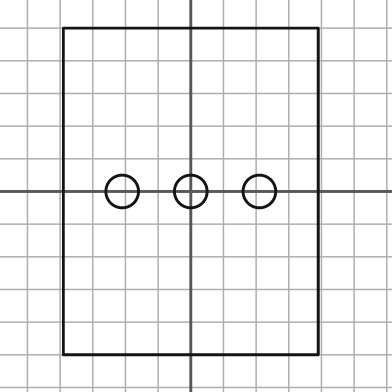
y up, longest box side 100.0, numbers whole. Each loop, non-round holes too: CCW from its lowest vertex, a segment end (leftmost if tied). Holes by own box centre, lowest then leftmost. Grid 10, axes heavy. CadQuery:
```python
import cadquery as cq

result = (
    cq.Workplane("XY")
    .moveTo(-39.0, -50.0)
    .lineTo(39.0, -50.0)
    .lineTo(39.0, 50.0)
    .lineTo(-39.0, 50.0)
    .close()
    .moveTo(-21.0, 0.0)
    .circle(5.0)
    .moveTo(0.0, 0.0)
    .circle(5.0)
    .moveTo(21.0, 0.0)
    .circle(5.0)
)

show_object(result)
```